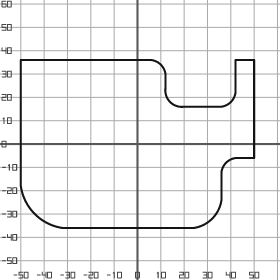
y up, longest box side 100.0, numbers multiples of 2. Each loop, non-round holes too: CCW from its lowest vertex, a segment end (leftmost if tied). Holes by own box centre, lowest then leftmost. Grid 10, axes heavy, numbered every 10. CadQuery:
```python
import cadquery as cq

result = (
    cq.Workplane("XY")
    .moveTo(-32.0, -36.0)
    .lineTo(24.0, -36.0)
    .threePointArc((32.0, -32.0), (36.0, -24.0))
    .lineTo(36.0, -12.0)
    .threePointArc((38.0, -8.0), (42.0, -6.0))
    .lineTo(50.0, -6.0)
    .lineTo(50.0, 36.0)
    .lineTo(42.0, 36.0)
    .lineTo(42.0, 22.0)
    .threePointArc((40.0, 18.0), (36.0, 16.0))
    .lineTo(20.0, 16.0)
    .threePointArc((14.0, 18.0), (12.0, 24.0))
    .lineTo(12.0, 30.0)
    .threePointArc((10.0, 34.0), (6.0, 36.0))
    .lineTo(-50.0, 36.0)
    .lineTo(-50.0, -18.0)
    .threePointArc((-44.0, -30.0), (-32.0, -36.0))
    .close()
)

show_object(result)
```